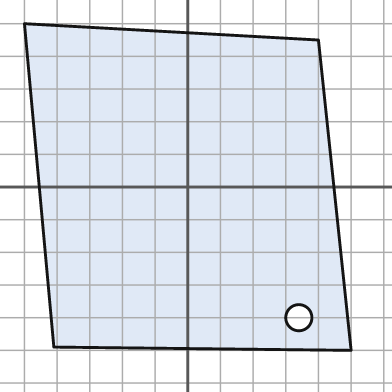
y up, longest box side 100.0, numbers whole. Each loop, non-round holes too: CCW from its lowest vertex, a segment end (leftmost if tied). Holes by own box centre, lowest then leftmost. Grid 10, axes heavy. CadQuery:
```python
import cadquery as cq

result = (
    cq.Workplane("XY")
    .moveTo(50.0, -50.0)
    .lineTo(40.0, 45.0)
    .lineTo(-50.0, 50.0)
    .lineTo(-41.0, -49.0)
    .close()
    .moveTo(34.0, -40.0)
    .circle(4.0)
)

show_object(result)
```